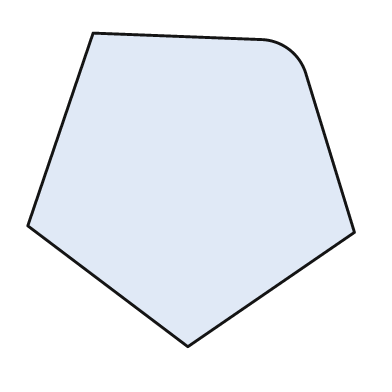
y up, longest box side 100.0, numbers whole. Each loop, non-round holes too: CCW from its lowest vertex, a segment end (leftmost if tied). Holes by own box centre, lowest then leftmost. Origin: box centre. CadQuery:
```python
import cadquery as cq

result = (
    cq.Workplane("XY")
    .moveTo(-1.0, -48.0)
    .lineTo(50.0, -13.0)
    .lineTo(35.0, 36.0)
    .threePointArc((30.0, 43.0), (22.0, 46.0))
    .lineTo(-30.0, 48.0)
    .lineTo(-50.0, -11.0)
    .close()
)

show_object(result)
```